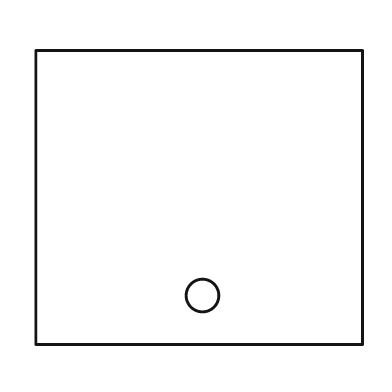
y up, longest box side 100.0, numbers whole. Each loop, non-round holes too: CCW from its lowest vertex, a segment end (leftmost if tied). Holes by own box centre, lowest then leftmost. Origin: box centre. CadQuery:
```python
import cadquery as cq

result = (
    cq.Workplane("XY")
    .moveTo(-50.0, -45.0)
    .lineTo(50.0, -45.0)
    .lineTo(50.0, 45.0)
    .lineTo(-50.0, 45.0)
    .close()
    .moveTo(1.0, -30.0)
    .circle(5.0)
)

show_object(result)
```